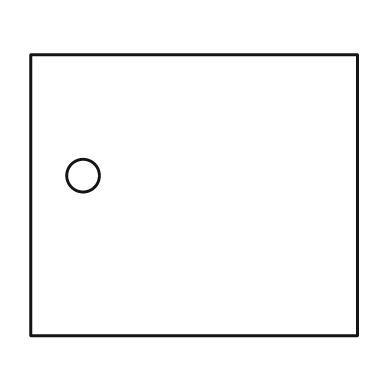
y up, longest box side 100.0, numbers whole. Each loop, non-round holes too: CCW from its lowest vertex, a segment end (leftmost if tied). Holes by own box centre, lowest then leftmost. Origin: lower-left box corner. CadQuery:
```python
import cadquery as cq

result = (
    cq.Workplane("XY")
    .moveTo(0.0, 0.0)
    .lineTo(100.0, 0.0)
    .lineTo(100.0, 86.0)
    .lineTo(0.0, 86.0)
    .close()
    .moveTo(16.0, 49.0)
    .circle(5.0)
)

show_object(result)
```